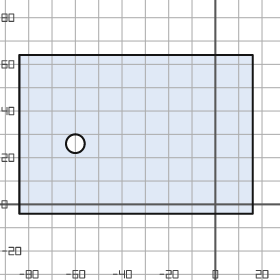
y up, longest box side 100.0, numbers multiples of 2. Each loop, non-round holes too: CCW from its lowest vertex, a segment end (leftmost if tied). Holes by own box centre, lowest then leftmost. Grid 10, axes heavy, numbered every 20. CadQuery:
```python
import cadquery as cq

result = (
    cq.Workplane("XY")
    .moveTo(-84.0, -4.0)
    .lineTo(16.0, -4.0)
    .lineTo(16.0, 64.0)
    .lineTo(-84.0, 64.0)
    .close()
    .moveTo(-60.0, 26.0)
    .circle(4.0)
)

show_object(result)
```